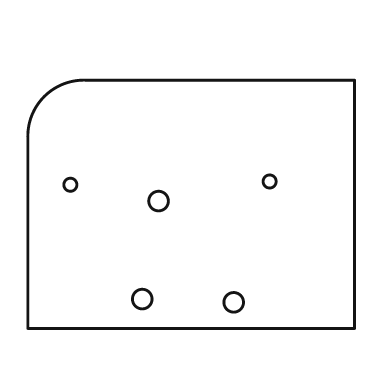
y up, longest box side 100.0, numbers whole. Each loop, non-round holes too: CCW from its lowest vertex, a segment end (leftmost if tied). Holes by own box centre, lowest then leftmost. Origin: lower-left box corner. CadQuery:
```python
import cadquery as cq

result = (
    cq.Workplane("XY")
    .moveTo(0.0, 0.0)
    .lineTo(100.0, 0.0)
    .lineTo(100.0, 76.0)
    .lineTo(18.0, 76.0)
    .threePointArc((5.0, 71.0), (0.0, 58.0))
    .close()
    .moveTo(63.0, 8.0)
    .circle(3.0)
    .moveTo(35.0, 9.0)
    .circle(3.0)
    .moveTo(40.0, 39.0)
    .circle(3.0)
    .moveTo(13.0, 44.0)
    .circle(2.0)
    .moveTo(74.0, 45.0)
    .circle(2.0)
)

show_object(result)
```